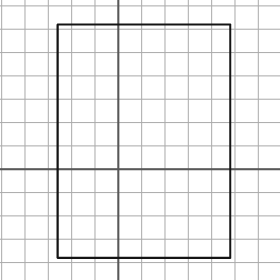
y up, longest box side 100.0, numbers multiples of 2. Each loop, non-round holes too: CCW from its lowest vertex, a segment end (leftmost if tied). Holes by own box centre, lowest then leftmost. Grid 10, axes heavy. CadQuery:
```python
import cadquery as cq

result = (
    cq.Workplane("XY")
    .moveTo(-26.0, -38.0)
    .lineTo(48.0, -38.0)
    .lineTo(48.0, 62.0)
    .lineTo(-26.0, 62.0)
    .close()
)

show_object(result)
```